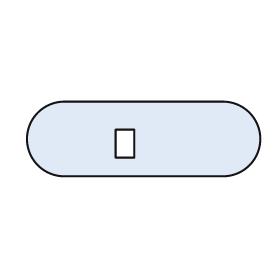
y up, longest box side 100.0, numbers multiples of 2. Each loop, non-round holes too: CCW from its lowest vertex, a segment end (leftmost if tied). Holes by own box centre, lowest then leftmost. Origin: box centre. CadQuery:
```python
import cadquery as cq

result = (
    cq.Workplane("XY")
    .moveTo(-34.0, -16.0)
    .lineTo(34.0, -16.0)
    .threePointArc((50.0, 0.0), (34.0, 16.0))
    .lineTo(-34.0, 16.0)
    .threePointArc((-50.0, 0.0), (-34.0, -16.0))
    .close()
    .moveTo(-12.0, -8.0)
    .lineTo(-4.0, -8.0)
    .lineTo(-4.0, 4.0)
    .lineTo(-12.0, 4.0)
    .close()
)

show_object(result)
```